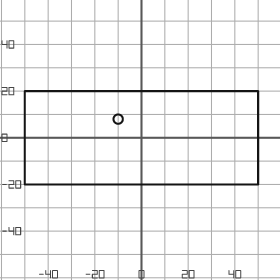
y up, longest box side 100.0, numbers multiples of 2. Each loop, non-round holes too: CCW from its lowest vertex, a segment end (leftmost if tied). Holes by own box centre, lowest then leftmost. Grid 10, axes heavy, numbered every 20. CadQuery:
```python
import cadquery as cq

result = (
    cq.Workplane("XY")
    .moveTo(-50.0, -20.0)
    .lineTo(50.0, -20.0)
    .lineTo(50.0, 20.0)
    .lineTo(-50.0, 20.0)
    .close()
    .moveTo(-10.0, 8.0)
    .circle(2.0)
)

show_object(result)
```